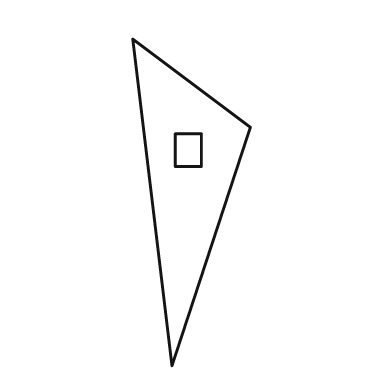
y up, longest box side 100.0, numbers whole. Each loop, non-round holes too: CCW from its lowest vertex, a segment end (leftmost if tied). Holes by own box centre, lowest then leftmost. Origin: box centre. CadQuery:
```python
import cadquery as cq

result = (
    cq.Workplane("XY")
    .moveTo(-6.0, -50.0)
    .lineTo(18.0, 23.0)
    .lineTo(-18.0, 50.0)
    .close()
    .moveTo(-5.0, 11.0)
    .lineTo(3.0, 11.0)
    .lineTo(3.0, 21.0)
    .lineTo(-5.0, 21.0)
    .close()
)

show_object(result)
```